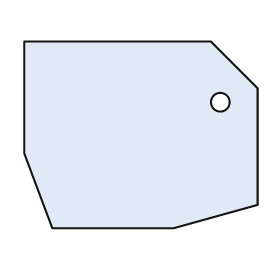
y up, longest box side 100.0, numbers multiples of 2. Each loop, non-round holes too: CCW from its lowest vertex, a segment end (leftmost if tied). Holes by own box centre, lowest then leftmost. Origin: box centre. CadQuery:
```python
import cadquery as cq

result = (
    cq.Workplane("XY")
    .moveTo(-38.0, -40.0)
    .lineTo(14.0, -40.0)
    .lineTo(50.0, -30.0)
    .lineTo(50.0, 20.0)
    .lineTo(30.0, 40.0)
    .lineTo(-50.0, 40.0)
    .lineTo(-50.0, -8.0)
    .close()
    .moveTo(34.0, 14.0)
    .circle(4.0)
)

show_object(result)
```